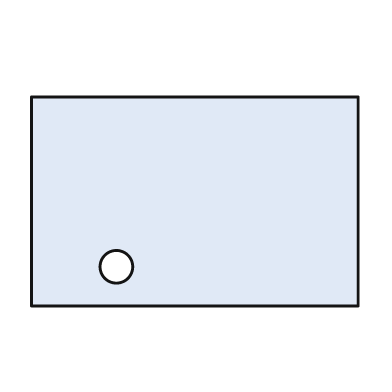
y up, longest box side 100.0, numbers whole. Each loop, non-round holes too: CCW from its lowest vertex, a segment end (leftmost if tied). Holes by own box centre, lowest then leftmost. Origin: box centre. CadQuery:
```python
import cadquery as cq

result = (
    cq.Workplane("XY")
    .moveTo(-50.0, -32.0)
    .lineTo(50.0, -32.0)
    .lineTo(50.0, 32.0)
    .lineTo(-50.0, 32.0)
    .close()
    .moveTo(-24.0, -20.0)
    .circle(5.0)
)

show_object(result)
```